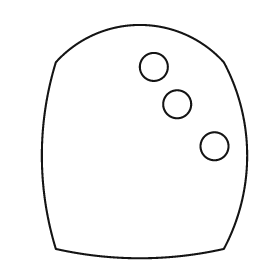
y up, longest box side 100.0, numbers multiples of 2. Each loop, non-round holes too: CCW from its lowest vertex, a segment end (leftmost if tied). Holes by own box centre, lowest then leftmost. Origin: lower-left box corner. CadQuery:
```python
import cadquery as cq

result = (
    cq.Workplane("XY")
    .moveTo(6.0, 4.0)
    .threePointArc((42.0, 0.0), (78.0, 4.0))
    .threePointArc((88.0, 44.0), (78.0, 84.0))
    .threePointArc((42.0, 100.0), (6.0, 84.0))
    .threePointArc((0.0, 44.0), (6.0, 4.0))
    .close()
    .moveTo(74.0, 48.0)
    .circle(6.0)
    .moveTo(58.0, 66.0)
    .circle(6.0)
    .moveTo(48.0, 82.0)
    .circle(6.0)
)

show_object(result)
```